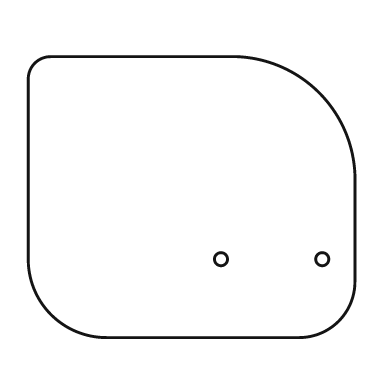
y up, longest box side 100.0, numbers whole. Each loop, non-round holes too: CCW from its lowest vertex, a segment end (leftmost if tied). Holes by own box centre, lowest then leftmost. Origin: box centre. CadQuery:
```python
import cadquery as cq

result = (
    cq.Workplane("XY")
    .moveTo(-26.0, -43.0)
    .lineTo(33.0, -43.0)
    .threePointArc((45.0, -38.0), (50.0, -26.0))
    .lineTo(50.0, 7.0)
    .threePointArc((39.0, 32.0), (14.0, 43.0))
    .lineTo(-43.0, 43.0)
    .threePointArc((-48.0, 41.0), (-50.0, 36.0))
    .lineTo(-50.0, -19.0)
    .threePointArc((-43.0, -36.0), (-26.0, -43.0))
    .close()
    .moveTo(9.0, -19.0)
    .circle(2.0)
    .moveTo(40.0, -19.0)
    .circle(2.0)
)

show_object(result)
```